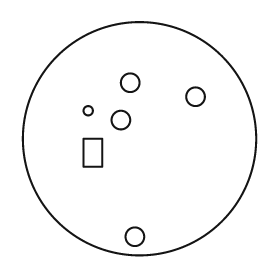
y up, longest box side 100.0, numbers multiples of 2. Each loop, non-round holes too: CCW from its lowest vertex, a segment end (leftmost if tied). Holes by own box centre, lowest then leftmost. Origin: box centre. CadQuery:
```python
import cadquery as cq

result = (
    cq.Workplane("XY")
    .moveTo(0.0, 0.0)
    .circle(50.0)
    .moveTo(-2.0, -42.0)
    .circle(4.0)
    .moveTo(-24.0, -12.0)
    .lineTo(-16.0, -12.0)
    .lineTo(-16.0, 0.0)
    .lineTo(-24.0, 0.0)
    .close()
    .moveTo(-8.0, 8.0)
    .circle(4.0)
    .moveTo(-22.0, 12.0)
    .circle(2.0)
    .moveTo(24.0, 18.0)
    .circle(4.0)
    .moveTo(-4.0, 24.0)
    .circle(4.0)
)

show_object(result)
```